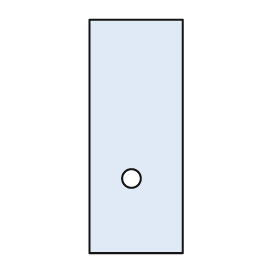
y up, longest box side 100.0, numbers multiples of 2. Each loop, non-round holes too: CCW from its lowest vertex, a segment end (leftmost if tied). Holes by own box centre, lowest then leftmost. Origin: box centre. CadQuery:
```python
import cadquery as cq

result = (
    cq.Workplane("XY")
    .moveTo(-20.0, -50.0)
    .lineTo(20.0, -50.0)
    .lineTo(20.0, 50.0)
    .lineTo(-20.0, 50.0)
    .close()
    .moveTo(-2.0, -18.0)
    .circle(4.0)
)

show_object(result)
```